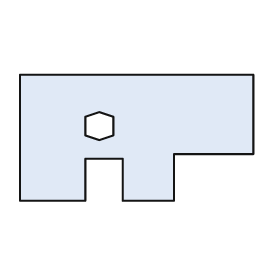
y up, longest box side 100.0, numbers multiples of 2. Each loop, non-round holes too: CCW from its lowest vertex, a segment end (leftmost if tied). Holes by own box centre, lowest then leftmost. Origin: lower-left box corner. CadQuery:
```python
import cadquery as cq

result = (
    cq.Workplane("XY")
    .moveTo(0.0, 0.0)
    .lineTo(28.0, 0.0)
    .lineTo(28.0, 18.0)
    .lineTo(44.0, 18.0)
    .lineTo(44.0, 0.0)
    .lineTo(66.0, 0.0)
    .lineTo(66.0, 20.0)
    .lineTo(100.0, 20.0)
    .lineTo(100.0, 54.0)
    .lineTo(0.0, 54.0)
    .close()
    .moveTo(34.0, 26.0)
    .lineTo(40.0, 28.0)
    .lineTo(40.0, 36.0)
    .lineTo(34.0, 38.0)
    .lineTo(28.0, 36.0)
    .lineTo(28.0, 28.0)
    .close()
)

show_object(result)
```